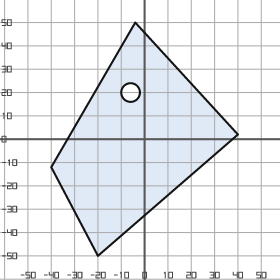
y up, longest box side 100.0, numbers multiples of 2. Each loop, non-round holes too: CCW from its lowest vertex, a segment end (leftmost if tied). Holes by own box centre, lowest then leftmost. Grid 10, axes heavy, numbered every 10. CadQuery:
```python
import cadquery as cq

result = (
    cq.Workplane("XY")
    .moveTo(-20.0, -50.0)
    .lineTo(40.0, 2.0)
    .lineTo(-4.0, 50.0)
    .lineTo(-40.0, -12.0)
    .close()
    .moveTo(-6.0, 20.0)
    .circle(4.0)
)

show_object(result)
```